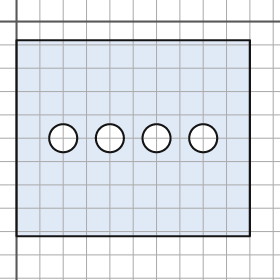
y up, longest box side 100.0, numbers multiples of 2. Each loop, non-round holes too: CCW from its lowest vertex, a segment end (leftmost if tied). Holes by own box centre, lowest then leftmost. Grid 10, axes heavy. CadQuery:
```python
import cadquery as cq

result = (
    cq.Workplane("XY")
    .moveTo(0.0, -92.0)
    .lineTo(100.0, -92.0)
    .lineTo(100.0, -8.0)
    .lineTo(0.0, -8.0)
    .close()
    .moveTo(20.0, -50.0)
    .circle(6.0)
    .moveTo(40.0, -50.0)
    .circle(6.0)
    .moveTo(60.0, -50.0)
    .circle(6.0)
    .moveTo(80.0, -50.0)
    .circle(6.0)
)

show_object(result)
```